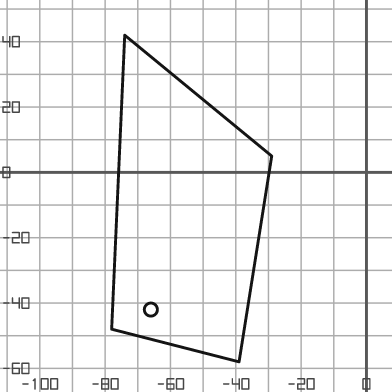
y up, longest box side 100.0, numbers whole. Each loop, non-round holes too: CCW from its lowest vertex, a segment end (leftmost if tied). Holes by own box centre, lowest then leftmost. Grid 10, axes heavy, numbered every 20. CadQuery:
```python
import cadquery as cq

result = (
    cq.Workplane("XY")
    .moveTo(-39.0, -58.0)
    .lineTo(-29.0, 5.0)
    .lineTo(-74.0, 42.0)
    .lineTo(-78.0, -48.0)
    .close()
    .moveTo(-66.0, -42.0)
    .circle(2.0)
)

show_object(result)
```